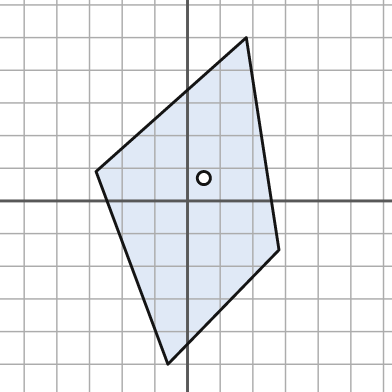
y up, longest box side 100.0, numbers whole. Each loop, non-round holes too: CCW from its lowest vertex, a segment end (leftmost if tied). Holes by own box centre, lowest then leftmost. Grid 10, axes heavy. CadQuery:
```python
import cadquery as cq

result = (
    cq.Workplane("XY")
    .moveTo(-6.0, -50.0)
    .lineTo(28.0, -15.0)
    .lineTo(18.0, 50.0)
    .lineTo(-28.0, 9.0)
    .close()
    .moveTo(5.0, 7.0)
    .circle(2.0)
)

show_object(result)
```